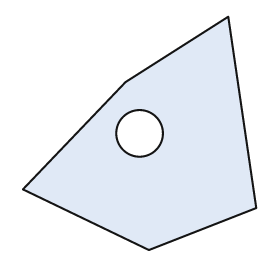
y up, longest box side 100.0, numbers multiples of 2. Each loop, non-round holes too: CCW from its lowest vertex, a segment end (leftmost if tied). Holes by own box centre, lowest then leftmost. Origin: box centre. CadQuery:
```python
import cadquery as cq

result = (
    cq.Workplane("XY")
    .moveTo(4.0, -50.0)
    .lineTo(50.0, -32.0)
    .lineTo(38.0, 50.0)
    .lineTo(-6.0, 22.0)
    .lineTo(-50.0, -24.0)
    .close()
    .moveTo(0.0, 0.0)
    .circle(10.0)
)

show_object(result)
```